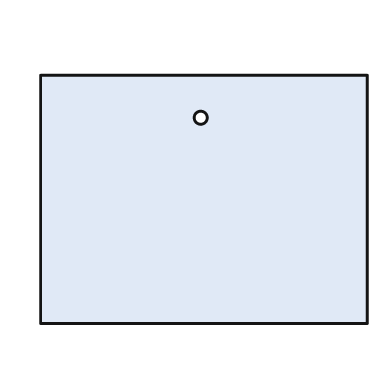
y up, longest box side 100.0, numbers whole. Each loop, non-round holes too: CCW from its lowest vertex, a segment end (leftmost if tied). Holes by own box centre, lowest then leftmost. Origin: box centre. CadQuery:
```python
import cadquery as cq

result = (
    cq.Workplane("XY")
    .moveTo(-50.0, -38.0)
    .lineTo(50.0, -38.0)
    .lineTo(50.0, 38.0)
    .lineTo(-50.0, 38.0)
    .close()
    .moveTo(-1.0, 25.0)
    .circle(2.0)
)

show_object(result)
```